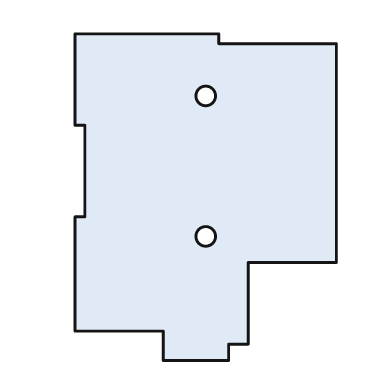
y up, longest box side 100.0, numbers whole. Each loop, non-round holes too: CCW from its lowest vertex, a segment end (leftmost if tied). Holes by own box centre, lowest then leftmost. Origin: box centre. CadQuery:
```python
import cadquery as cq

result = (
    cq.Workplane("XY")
    .moveTo(-13.0, -50.0)
    .lineTo(7.0, -50.0)
    .lineTo(7.0, -45.0)
    .lineTo(13.0, -45.0)
    .lineTo(13.0, -20.0)
    .lineTo(40.0, -20.0)
    .lineTo(40.0, 47.0)
    .lineTo(4.0, 47.0)
    .lineTo(4.0, 50.0)
    .lineTo(-40.0, 50.0)
    .lineTo(-40.0, 22.0)
    .lineTo(-37.0, 22.0)
    .lineTo(-37.0, -6.0)
    .lineTo(-40.0, -6.0)
    .lineTo(-40.0, -41.0)
    .lineTo(-13.0, -41.0)
    .close()
    .moveTo(0.0, -12.0)
    .circle(3.0)
    .moveTo(0.0, 31.0)
    .circle(3.0)
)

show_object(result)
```